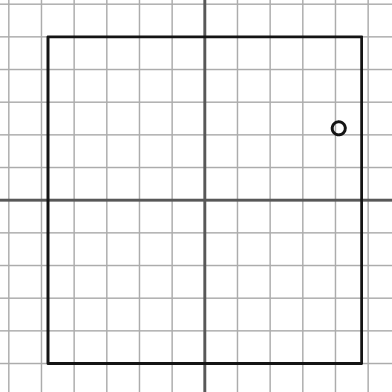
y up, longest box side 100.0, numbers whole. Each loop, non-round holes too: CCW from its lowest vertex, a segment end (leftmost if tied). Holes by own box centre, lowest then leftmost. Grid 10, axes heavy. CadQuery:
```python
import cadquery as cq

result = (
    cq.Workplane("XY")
    .moveTo(-48.0, -50.0)
    .lineTo(48.0, -50.0)
    .lineTo(48.0, 50.0)
    .lineTo(-48.0, 50.0)
    .close()
    .moveTo(41.0, 22.0)
    .circle(2.0)
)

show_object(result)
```